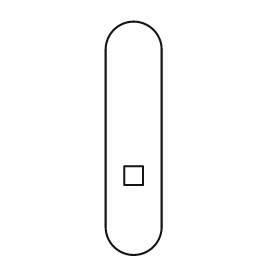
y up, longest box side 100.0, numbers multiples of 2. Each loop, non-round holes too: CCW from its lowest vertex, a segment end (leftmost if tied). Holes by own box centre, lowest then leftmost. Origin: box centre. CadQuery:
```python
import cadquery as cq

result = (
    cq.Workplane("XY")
    .moveTo(-12.0, -38.0)
    .threePointArc((0.0, -50.0), (12.0, -38.0))
    .lineTo(12.0, 38.0)
    .threePointArc((0.0, 50.0), (-12.0, 38.0))
    .close()
    .moveTo(-4.0, -20.0)
    .lineTo(4.0, -20.0)
    .lineTo(4.0, -12.0)
    .lineTo(-4.0, -12.0)
    .close()
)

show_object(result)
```